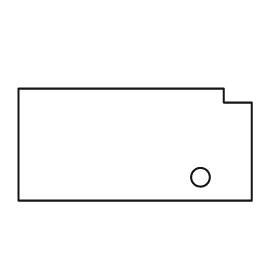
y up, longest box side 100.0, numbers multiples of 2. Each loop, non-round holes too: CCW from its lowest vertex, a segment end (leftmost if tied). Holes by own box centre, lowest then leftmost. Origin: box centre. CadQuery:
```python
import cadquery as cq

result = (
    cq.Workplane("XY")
    .moveTo(-50.0, -24.0)
    .lineTo(50.0, -24.0)
    .lineTo(50.0, 18.0)
    .lineTo(38.0, 18.0)
    .lineTo(38.0, 24.0)
    .lineTo(-50.0, 24.0)
    .close()
    .moveTo(28.0, -14.0)
    .circle(4.0)
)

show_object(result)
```